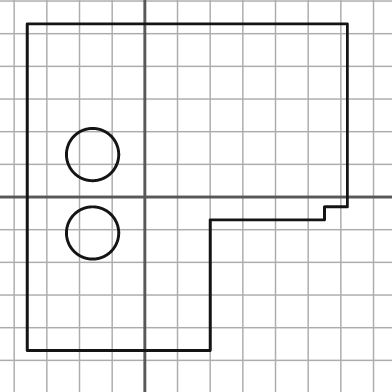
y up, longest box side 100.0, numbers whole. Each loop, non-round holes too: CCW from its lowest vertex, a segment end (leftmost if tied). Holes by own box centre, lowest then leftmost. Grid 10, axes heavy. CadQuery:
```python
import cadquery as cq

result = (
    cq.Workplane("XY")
    .moveTo(-36.0, -47.0)
    .lineTo(20.0, -47.0)
    .lineTo(20.0, -7.0)
    .lineTo(55.0, -7.0)
    .lineTo(55.0, -3.0)
    .lineTo(62.0, -3.0)
    .lineTo(62.0, 53.0)
    .lineTo(-36.0, 53.0)
    .close()
    .moveTo(-16.0, -11.0)
    .circle(8.0)
    .moveTo(-16.0, 13.0)
    .circle(8.0)
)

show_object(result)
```